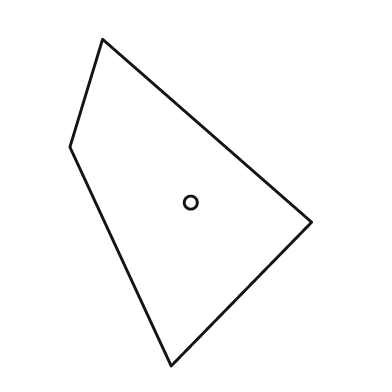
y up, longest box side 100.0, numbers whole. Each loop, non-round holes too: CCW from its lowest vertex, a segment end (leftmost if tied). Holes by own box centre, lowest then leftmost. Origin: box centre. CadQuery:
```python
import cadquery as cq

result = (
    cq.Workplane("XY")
    .moveTo(-6.0, -50.0)
    .lineTo(37.0, -6.0)
    .lineTo(-27.0, 50.0)
    .lineTo(-37.0, 17.0)
    .close()
    .moveTo(0.0, 0.0)
    .circle(2.0)
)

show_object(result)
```